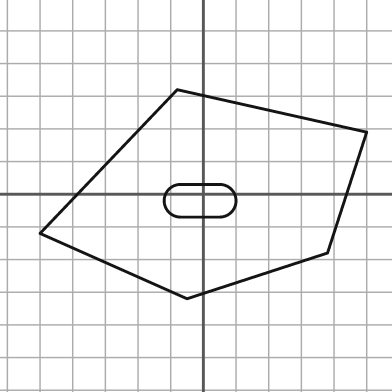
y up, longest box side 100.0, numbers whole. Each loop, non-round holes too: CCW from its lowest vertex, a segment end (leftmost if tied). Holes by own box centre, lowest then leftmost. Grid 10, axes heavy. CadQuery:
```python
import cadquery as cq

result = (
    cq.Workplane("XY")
    .moveTo(-5.0, -32.0)
    .lineTo(38.0, -18.0)
    .lineTo(50.0, 19.0)
    .lineTo(-8.0, 32.0)
    .lineTo(-50.0, -12.0)
    .close()
    .moveTo(-7.0, -7.0)
    .lineTo(5.0, -7.0)
    .threePointArc((10.0, -2.0), (5.0, 3.0))
    .lineTo(-7.0, 3.0)
    .threePointArc((-12.0, -2.0), (-7.0, -7.0))
    .close()
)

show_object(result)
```